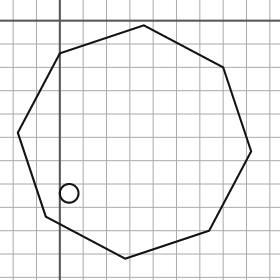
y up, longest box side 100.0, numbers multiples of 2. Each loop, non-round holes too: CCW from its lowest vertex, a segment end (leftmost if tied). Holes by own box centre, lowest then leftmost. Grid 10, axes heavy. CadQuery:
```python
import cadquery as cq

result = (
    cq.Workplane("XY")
    .moveTo(28.0, -102.0)
    .lineTo(64.0, -90.0)
    .lineTo(82.0, -56.0)
    .lineTo(70.0, -20.0)
    .lineTo(36.0, -2.0)
    .lineTo(0.0, -14.0)
    .lineTo(-18.0, -48.0)
    .lineTo(-6.0, -84.0)
    .close()
    .moveTo(4.0, -74.0)
    .circle(4.0)
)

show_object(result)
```